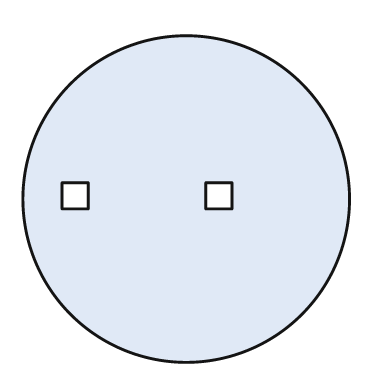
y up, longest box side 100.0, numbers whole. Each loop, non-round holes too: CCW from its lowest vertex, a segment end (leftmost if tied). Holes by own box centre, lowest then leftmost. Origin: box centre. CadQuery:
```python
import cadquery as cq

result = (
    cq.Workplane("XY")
    .moveTo(0.0, 0.0)
    .circle(50.0)
    .moveTo(-38.0, -3.0)
    .lineTo(-30.0, -3.0)
    .lineTo(-30.0, 5.0)
    .lineTo(-38.0, 5.0)
    .close()
    .moveTo(6.0, -3.0)
    .lineTo(14.0, -3.0)
    .lineTo(14.0, 5.0)
    .lineTo(6.0, 5.0)
    .close()
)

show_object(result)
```